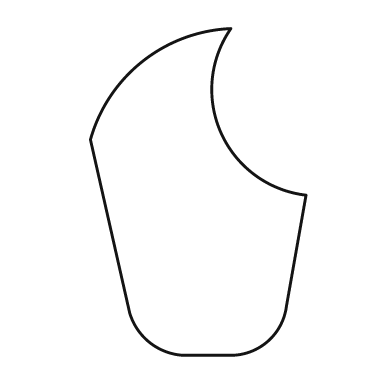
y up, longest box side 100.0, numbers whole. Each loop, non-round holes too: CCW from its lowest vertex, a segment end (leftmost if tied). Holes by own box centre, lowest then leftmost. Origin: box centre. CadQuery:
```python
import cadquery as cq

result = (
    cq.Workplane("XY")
    .moveTo(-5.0, -50.0)
    .lineTo(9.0, -50.0)
    .threePointArc((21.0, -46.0), (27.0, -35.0))
    .lineTo(33.0, -1.0)
    .threePointArc((7.0, 18.0), (10.0, 50.0))
    .threePointArc((-17.0, 40.0), (-33.0, 16.0))
    .lineTo(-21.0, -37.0)
    .threePointArc((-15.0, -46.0), (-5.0, -50.0))
    .close()
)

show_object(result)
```